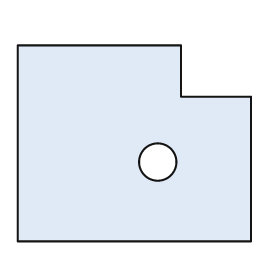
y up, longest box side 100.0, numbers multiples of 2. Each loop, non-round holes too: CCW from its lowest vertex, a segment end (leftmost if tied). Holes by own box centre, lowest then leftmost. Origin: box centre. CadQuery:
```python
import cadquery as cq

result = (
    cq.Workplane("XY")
    .moveTo(-50.0, -42.0)
    .lineTo(50.0, -42.0)
    .lineTo(50.0, 20.0)
    .lineTo(20.0, 20.0)
    .lineTo(20.0, 42.0)
    .lineTo(-50.0, 42.0)
    .close()
    .moveTo(10.0, -8.0)
    .circle(8.0)
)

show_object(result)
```